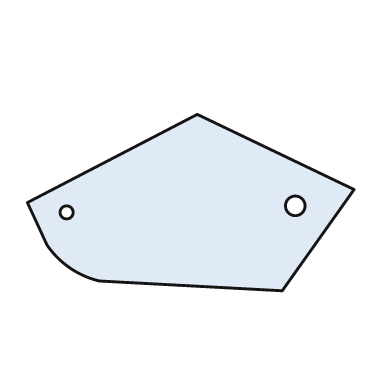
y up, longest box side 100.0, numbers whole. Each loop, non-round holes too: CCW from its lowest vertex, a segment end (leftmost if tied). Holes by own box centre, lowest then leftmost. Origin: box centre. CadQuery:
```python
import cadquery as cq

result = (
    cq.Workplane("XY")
    .moveTo(28.0, -27.0)
    .lineTo(50.0, 4.0)
    .lineTo(2.0, 27.0)
    .lineTo(-50.0, 0.0)
    .lineTo(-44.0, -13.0)
    .threePointArc((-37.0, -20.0), (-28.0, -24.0))
    .close()
    .moveTo(-38.0, -3.0)
    .circle(2.0)
    .moveTo(32.0, -1.0)
    .circle(3.0)
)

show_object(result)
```